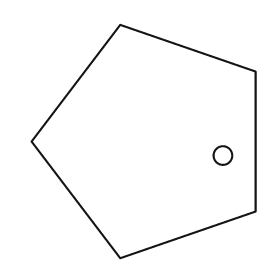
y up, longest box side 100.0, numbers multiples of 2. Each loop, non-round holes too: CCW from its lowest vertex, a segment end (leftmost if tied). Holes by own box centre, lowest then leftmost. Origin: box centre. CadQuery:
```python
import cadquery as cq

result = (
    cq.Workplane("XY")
    .moveTo(-10.0, -50.0)
    .lineTo(48.0, -30.0)
    .lineTo(48.0, 30.0)
    .lineTo(-10.0, 50.0)
    .lineTo(-48.0, 0.0)
    .close()
    .moveTo(34.0, -6.0)
    .circle(4.0)
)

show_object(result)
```